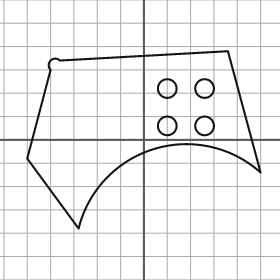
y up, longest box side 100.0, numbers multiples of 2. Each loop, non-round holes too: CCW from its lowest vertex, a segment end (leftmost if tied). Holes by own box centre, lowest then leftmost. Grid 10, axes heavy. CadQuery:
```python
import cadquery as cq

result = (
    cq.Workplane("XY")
    .moveTo(-28.0, -38.0)
    .threePointArc((4.0, -4.0), (50.0, -14.0))
    .lineTo(36.0, 38.0)
    .lineTo(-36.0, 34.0)
    .threePointArc((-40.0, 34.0), (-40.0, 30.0))
    .lineTo(-50.0, -8.0)
    .close()
    .moveTo(10.0, 6.0)
    .circle(4.0)
    .moveTo(26.0, 6.0)
    .circle(4.0)
    .moveTo(10.0, 22.0)
    .circle(4.0)
    .moveTo(26.0, 22.0)
    .circle(4.0)
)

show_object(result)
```